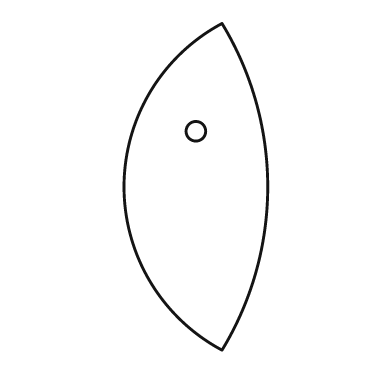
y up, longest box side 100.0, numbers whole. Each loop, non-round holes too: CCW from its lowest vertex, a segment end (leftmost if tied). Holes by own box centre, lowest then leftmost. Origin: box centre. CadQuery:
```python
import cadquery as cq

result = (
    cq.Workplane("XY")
    .moveTo(8.0, -50.0)
    .threePointArc((22.0, 0.0), (8.0, 50.0))
    .threePointArc((-22.0, 0.0), (8.0, -50.0))
    .close()
    .moveTo(0.0, 17.0)
    .circle(3.0)
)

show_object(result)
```